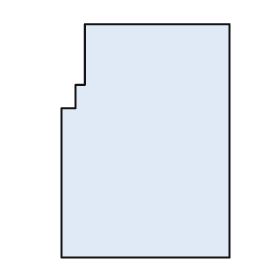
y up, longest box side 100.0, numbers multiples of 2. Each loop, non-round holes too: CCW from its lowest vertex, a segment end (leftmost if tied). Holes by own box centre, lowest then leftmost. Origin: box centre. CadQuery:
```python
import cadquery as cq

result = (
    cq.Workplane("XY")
    .moveTo(-36.0, -50.0)
    .lineTo(36.0, -50.0)
    .lineTo(36.0, 50.0)
    .lineTo(-26.0, 50.0)
    .lineTo(-26.0, 24.0)
    .lineTo(-30.0, 24.0)
    .lineTo(-30.0, 14.0)
    .lineTo(-36.0, 14.0)
    .close()
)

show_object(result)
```